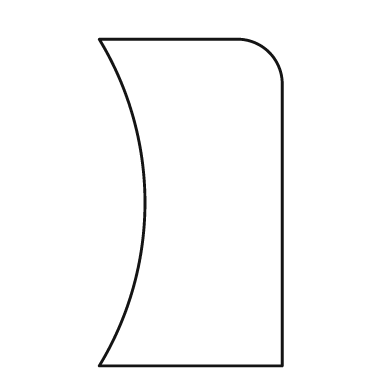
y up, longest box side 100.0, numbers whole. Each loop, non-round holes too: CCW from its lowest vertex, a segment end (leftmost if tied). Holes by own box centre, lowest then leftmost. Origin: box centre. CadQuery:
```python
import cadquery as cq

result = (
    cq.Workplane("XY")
    .moveTo(-28.0, -50.0)
    .lineTo(28.0, -50.0)
    .lineTo(28.0, 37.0)
    .threePointArc((24.0, 46.0), (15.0, 50.0))
    .lineTo(-28.0, 50.0)
    .threePointArc((-14.0, 0.0), (-28.0, -50.0))
    .close()
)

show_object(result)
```